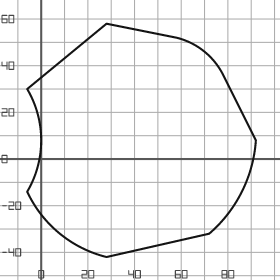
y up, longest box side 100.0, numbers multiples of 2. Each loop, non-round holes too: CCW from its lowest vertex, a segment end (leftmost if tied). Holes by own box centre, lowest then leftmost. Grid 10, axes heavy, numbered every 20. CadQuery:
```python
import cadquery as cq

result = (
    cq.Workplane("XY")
    .moveTo(28.0, -42.0)
    .lineTo(72.0, -32.0)
    .threePointArc((86.0, -14.0), (92.0, 8.0))
    .lineTo(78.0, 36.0)
    .threePointArc((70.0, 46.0), (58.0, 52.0))
    .lineTo(28.0, 58.0)
    .lineTo(-6.0, 30.0)
    .threePointArc((0.0, 8.0), (-6.0, -14.0))
    .threePointArc((8.0, -32.0), (28.0, -42.0))
    .close()
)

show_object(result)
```